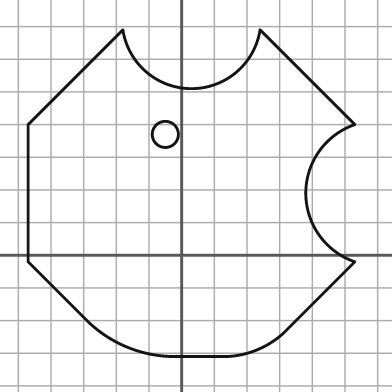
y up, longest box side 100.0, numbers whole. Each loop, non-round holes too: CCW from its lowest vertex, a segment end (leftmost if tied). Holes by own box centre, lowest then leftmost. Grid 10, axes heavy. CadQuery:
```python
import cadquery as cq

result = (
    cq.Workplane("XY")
    .moveTo(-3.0, -31.0)
    .lineTo(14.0, -31.0)
    .threePointArc((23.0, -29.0), (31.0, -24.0))
    .lineTo(53.0, -2.0)
    .threePointArc((38.0, 19.0), (53.0, 40.0))
    .lineTo(24.0, 69.0)
    .threePointArc((3.0, 51.0), (-18.0, 69.0))
    .lineTo(-47.0, 40.0)
    .lineTo(-47.0, -2.0)
    .lineTo(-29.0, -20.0)
    .threePointArc((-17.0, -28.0), (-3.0, -31.0))
    .close()
    .moveTo(-5.0, 37.0)
    .circle(4.0)
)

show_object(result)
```